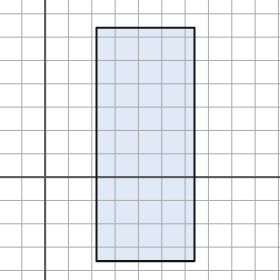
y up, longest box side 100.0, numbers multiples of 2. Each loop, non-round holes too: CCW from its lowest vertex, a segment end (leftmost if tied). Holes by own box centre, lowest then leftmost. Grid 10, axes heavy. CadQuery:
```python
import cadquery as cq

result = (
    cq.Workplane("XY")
    .moveTo(22.0, -36.0)
    .lineTo(64.0, -36.0)
    .lineTo(64.0, 64.0)
    .lineTo(22.0, 64.0)
    .close()
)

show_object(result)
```